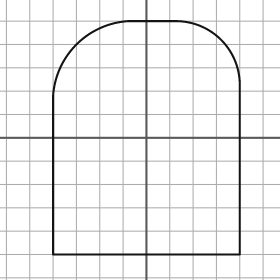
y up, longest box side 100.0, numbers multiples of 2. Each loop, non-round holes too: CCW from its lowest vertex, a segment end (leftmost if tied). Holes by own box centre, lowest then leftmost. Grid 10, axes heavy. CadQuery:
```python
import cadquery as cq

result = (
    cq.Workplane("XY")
    .moveTo(-40.0, -50.0)
    .lineTo(40.0, -50.0)
    .lineTo(40.0, 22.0)
    .threePointArc((32.0, 42.0), (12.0, 50.0))
    .lineTo(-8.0, 50.0)
    .threePointArc((-30.0, 40.0), (-40.0, 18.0))
    .close()
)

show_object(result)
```